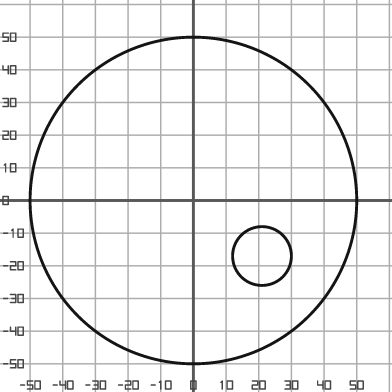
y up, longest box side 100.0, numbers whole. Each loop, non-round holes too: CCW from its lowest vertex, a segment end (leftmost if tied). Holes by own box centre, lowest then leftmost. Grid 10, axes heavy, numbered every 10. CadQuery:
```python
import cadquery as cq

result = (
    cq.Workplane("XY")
    .moveTo(0.0, 0.0)
    .circle(50.0)
    .moveTo(21.0, -17.0)
    .circle(9.0)
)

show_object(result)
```